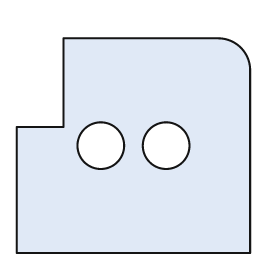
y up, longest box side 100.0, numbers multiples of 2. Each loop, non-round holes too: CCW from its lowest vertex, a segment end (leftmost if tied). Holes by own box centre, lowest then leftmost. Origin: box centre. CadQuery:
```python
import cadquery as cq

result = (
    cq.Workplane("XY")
    .moveTo(-50.0, -46.0)
    .lineTo(50.0, -46.0)
    .lineTo(50.0, 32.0)
    .threePointArc((46.0, 42.0), (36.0, 46.0))
    .lineTo(-30.0, 46.0)
    .lineTo(-30.0, 8.0)
    .lineTo(-50.0, 8.0)
    .close()
    .moveTo(-14.0, 0.0)
    .circle(10.0)
    .moveTo(14.0, 0.0)
    .circle(10.0)
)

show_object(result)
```